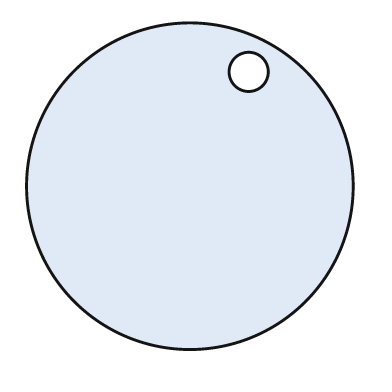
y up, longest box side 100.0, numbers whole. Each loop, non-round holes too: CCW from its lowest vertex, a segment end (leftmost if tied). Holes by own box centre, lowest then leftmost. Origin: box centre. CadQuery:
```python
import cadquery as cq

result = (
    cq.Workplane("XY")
    .moveTo(0.0, 0.0)
    .circle(50.0)
    .moveTo(18.0, 35.0)
    .circle(6.0)
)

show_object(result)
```